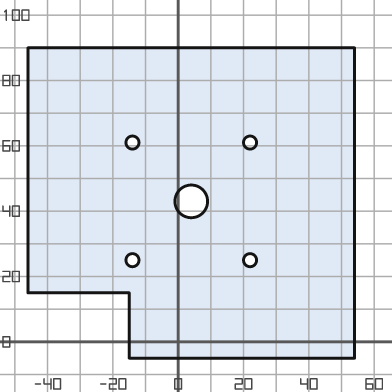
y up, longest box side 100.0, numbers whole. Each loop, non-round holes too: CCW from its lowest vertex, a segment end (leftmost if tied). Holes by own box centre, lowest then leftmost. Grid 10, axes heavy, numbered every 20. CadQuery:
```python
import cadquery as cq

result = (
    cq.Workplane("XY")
    .moveTo(-15.0, -5.0)
    .lineTo(54.0, -5.0)
    .lineTo(54.0, 90.0)
    .lineTo(-46.0, 90.0)
    .lineTo(-46.0, 15.0)
    .lineTo(-15.0, 15.0)
    .close()
    .moveTo(-14.0, 25.0)
    .circle(2.0)
    .moveTo(22.0, 25.0)
    .circle(2.0)
    .moveTo(4.0, 43.0)
    .circle(5.0)
    .moveTo(-14.0, 61.0)
    .circle(2.0)
    .moveTo(22.0, 61.0)
    .circle(2.0)
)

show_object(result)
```